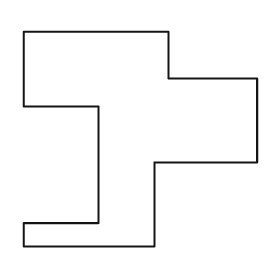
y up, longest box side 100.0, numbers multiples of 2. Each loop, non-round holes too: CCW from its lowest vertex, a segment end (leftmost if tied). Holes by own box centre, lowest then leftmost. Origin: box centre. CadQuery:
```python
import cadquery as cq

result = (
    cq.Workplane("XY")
    .moveTo(-50.0, -46.0)
    .lineTo(6.0, -46.0)
    .lineTo(6.0, -10.0)
    .lineTo(50.0, -10.0)
    .lineTo(50.0, 26.0)
    .lineTo(12.0, 26.0)
    .lineTo(12.0, 46.0)
    .lineTo(-50.0, 46.0)
    .lineTo(-50.0, 14.0)
    .lineTo(-18.0, 14.0)
    .lineTo(-18.0, -36.0)
    .lineTo(-50.0, -36.0)
    .close()
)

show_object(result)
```